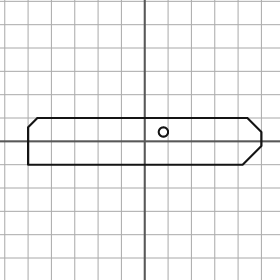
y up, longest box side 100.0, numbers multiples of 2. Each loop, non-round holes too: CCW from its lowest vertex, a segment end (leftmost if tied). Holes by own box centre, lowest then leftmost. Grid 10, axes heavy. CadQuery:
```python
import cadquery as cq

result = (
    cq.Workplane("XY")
    .moveTo(-50.0, -10.0)
    .lineTo(42.0, -10.0)
    .lineTo(50.0, -2.0)
    .lineTo(50.0, 4.0)
    .lineTo(44.0, 10.0)
    .lineTo(-46.0, 10.0)
    .lineTo(-50.0, 6.0)
    .close()
    .moveTo(8.0, 4.0)
    .circle(2.0)
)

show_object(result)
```